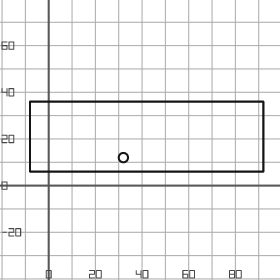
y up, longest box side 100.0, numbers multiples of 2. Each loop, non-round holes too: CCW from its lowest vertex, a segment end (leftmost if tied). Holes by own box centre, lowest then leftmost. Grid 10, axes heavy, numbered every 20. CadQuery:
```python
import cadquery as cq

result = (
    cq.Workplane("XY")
    .moveTo(-8.0, 6.0)
    .lineTo(92.0, 6.0)
    .lineTo(92.0, 36.0)
    .lineTo(-8.0, 36.0)
    .close()
    .moveTo(32.0, 12.0)
    .circle(2.0)
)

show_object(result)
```